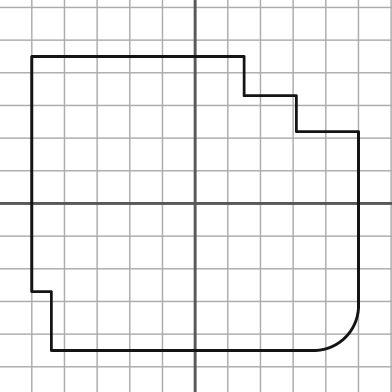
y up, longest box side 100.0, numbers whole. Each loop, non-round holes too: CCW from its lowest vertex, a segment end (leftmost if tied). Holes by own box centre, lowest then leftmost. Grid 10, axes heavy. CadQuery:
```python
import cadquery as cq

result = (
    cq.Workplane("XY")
    .moveTo(-44.0, -45.0)
    .lineTo(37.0, -45.0)
    .threePointArc((46.0, -41.0), (50.0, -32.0))
    .lineTo(50.0, 22.0)
    .lineTo(31.0, 22.0)
    .lineTo(31.0, 33.0)
    .lineTo(15.0, 33.0)
    .lineTo(15.0, 45.0)
    .lineTo(-50.0, 45.0)
    .lineTo(-50.0, -27.0)
    .lineTo(-44.0, -27.0)
    .close()
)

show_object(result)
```